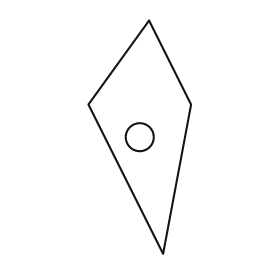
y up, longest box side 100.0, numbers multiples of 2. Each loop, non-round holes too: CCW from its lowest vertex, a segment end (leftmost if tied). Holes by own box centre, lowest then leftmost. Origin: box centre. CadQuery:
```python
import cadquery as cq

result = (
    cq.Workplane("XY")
    .moveTo(10.0, -50.0)
    .lineTo(22.0, 14.0)
    .lineTo(4.0, 50.0)
    .lineTo(-22.0, 14.0)
    .close()
    .moveTo(0.0, 0.0)
    .circle(6.0)
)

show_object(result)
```